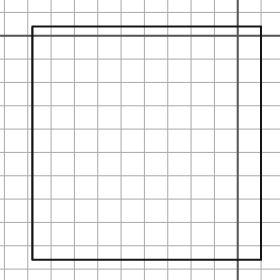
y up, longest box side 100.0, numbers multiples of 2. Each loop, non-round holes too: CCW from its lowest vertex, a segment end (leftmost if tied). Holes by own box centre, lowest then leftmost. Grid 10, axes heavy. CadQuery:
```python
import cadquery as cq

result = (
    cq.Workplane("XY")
    .moveTo(-88.0, -96.0)
    .lineTo(10.0, -96.0)
    .lineTo(10.0, 4.0)
    .lineTo(-88.0, 4.0)
    .close()
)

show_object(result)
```